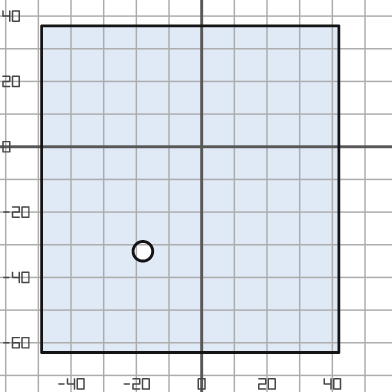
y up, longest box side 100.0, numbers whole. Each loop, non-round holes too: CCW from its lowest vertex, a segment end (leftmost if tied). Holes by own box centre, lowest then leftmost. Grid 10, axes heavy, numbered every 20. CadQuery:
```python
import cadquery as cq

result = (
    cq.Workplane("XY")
    .moveTo(-49.0, -63.0)
    .lineTo(42.0, -63.0)
    .lineTo(42.0, 37.0)
    .lineTo(-49.0, 37.0)
    .close()
    .moveTo(-18.0, -32.0)
    .circle(3.0)
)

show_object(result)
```